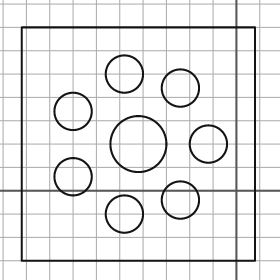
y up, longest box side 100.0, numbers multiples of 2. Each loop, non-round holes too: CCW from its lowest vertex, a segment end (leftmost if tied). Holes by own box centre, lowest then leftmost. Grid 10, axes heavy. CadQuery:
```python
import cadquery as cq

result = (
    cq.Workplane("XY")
    .moveTo(-92.0, -30.0)
    .lineTo(8.0, -30.0)
    .lineTo(8.0, 70.0)
    .lineTo(-92.0, 70.0)
    .close()
    .moveTo(-48.0, -10.0)
    .circle(8.0)
    .moveTo(-24.0, -4.0)
    .circle(8.0)
    .moveTo(-70.0, 6.0)
    .circle(8.0)
    .moveTo(-42.0, 20.0)
    .circle(12.0)
    .moveTo(-12.0, 20.0)
    .circle(8.0)
    .moveTo(-70.0, 34.0)
    .circle(8.0)
    .moveTo(-24.0, 44.0)
    .circle(8.0)
    .moveTo(-48.0, 50.0)
    .circle(8.0)
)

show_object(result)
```